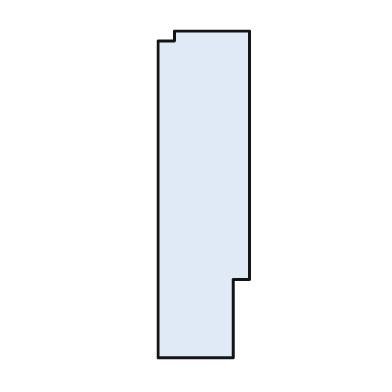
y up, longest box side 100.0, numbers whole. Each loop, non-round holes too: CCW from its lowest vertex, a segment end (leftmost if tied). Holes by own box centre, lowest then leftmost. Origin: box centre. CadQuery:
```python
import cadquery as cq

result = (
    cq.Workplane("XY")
    .moveTo(-14.0, -50.0)
    .lineTo(9.0, -50.0)
    .lineTo(9.0, -26.0)
    .lineTo(14.0, -26.0)
    .lineTo(14.0, 50.0)
    .lineTo(-9.0, 50.0)
    .lineTo(-9.0, 47.0)
    .lineTo(-14.0, 47.0)
    .close()
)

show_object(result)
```